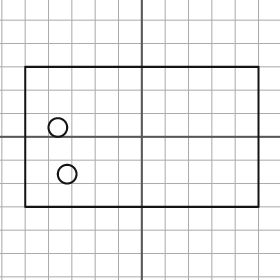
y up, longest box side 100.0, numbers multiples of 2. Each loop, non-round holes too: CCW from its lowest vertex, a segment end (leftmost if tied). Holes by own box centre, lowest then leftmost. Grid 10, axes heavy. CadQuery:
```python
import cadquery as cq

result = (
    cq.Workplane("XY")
    .moveTo(-50.0, -30.0)
    .lineTo(50.0, -30.0)
    .lineTo(50.0, 30.0)
    .lineTo(-50.0, 30.0)
    .close()
    .moveTo(-32.0, -16.0)
    .circle(4.0)
    .moveTo(-36.0, 4.0)
    .circle(4.0)
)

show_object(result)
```